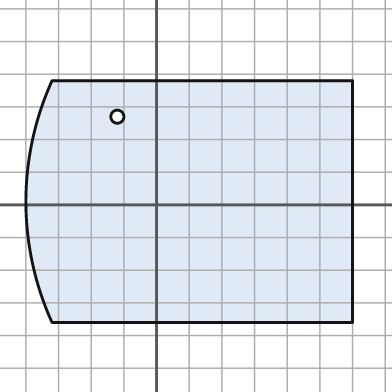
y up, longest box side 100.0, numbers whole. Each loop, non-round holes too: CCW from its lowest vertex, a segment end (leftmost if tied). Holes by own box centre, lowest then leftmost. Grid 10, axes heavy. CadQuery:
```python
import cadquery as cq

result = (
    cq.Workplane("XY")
    .moveTo(-32.0, -36.0)
    .lineTo(60.0, -36.0)
    .lineTo(60.0, 38.0)
    .lineTo(-32.0, 38.0)
    .threePointArc((-40.0, 1.0), (-32.0, -36.0))
    .close()
    .moveTo(-12.0, 27.0)
    .circle(2.0)
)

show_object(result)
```